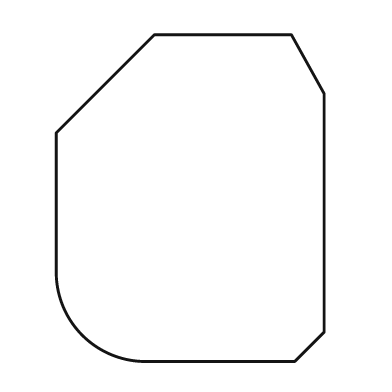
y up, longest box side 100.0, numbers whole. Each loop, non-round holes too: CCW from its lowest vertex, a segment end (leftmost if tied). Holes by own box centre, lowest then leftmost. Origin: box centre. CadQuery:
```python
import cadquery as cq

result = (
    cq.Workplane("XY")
    .moveTo(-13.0, -50.0)
    .lineTo(32.0, -50.0)
    .lineTo(41.0, -41.0)
    .lineTo(41.0, 32.0)
    .lineTo(31.0, 50.0)
    .lineTo(-11.0, 50.0)
    .lineTo(-41.0, 20.0)
    .lineTo(-41.0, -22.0)
    .threePointArc((-33.0, -42.0), (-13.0, -50.0))
    .close()
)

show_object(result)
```